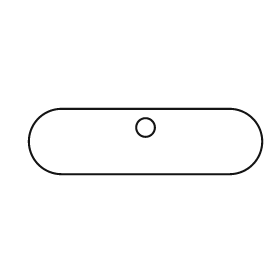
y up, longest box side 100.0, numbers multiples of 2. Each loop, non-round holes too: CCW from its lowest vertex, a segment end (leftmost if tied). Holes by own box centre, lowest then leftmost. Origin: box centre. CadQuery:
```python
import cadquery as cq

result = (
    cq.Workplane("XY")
    .moveTo(-36.0, -14.0)
    .lineTo(36.0, -14.0)
    .threePointArc((50.0, 0.0), (36.0, 14.0))
    .lineTo(-36.0, 14.0)
    .threePointArc((-50.0, 0.0), (-36.0, -14.0))
    .close()
    .moveTo(0.0, 6.0)
    .circle(4.0)
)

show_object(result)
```